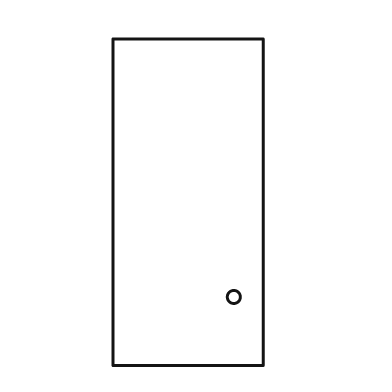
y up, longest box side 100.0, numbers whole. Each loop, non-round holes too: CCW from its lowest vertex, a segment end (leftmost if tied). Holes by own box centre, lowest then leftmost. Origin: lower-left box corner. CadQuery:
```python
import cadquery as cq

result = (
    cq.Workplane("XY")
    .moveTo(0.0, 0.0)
    .lineTo(46.0, 0.0)
    .lineTo(46.0, 100.0)
    .lineTo(0.0, 100.0)
    .close()
    .moveTo(37.0, 21.0)
    .circle(2.0)
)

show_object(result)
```